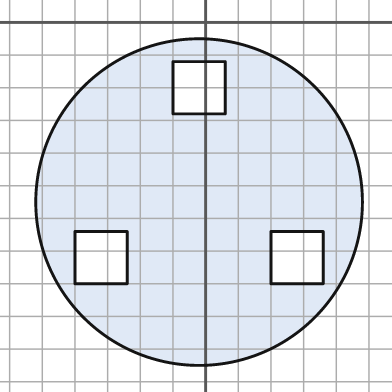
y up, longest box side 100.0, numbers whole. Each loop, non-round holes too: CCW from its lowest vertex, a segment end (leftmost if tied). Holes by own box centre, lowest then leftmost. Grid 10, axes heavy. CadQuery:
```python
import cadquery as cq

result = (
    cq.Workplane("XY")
    .moveTo(-2.0, -55.0)
    .circle(50.0)
    .moveTo(-40.0, -80.0)
    .lineTo(-24.0, -80.0)
    .lineTo(-24.0, -64.0)
    .lineTo(-40.0, -64.0)
    .close()
    .moveTo(20.0, -80.0)
    .lineTo(36.0, -80.0)
    .lineTo(36.0, -64.0)
    .lineTo(20.0, -64.0)
    .close()
    .moveTo(-10.0, -28.0)
    .lineTo(6.0, -28.0)
    .lineTo(6.0, -12.0)
    .lineTo(-10.0, -12.0)
    .close()
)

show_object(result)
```